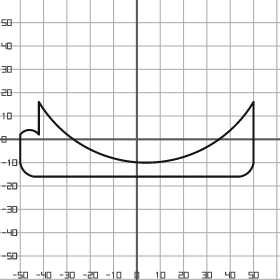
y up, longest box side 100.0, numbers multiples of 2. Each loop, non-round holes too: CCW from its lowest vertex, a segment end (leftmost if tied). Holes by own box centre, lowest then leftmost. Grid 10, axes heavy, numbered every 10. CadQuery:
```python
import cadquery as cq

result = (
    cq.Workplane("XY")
    .moveTo(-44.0, -16.0)
    .lineTo(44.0, -16.0)
    .threePointArc((48.0, -14.0), (50.0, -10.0))
    .lineTo(50.0, 16.0)
    .threePointArc((4.0, -10.0), (-42.0, 16.0))
    .lineTo(-42.0, 2.0)
    .threePointArc((-46.0, 4.0), (-50.0, 2.0))
    .lineTo(-50.0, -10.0)
    .threePointArc((-48.0, -14.0), (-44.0, -16.0))
    .close()
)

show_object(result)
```